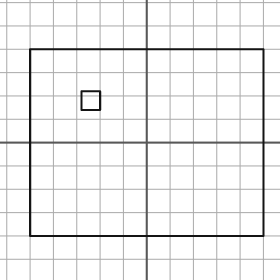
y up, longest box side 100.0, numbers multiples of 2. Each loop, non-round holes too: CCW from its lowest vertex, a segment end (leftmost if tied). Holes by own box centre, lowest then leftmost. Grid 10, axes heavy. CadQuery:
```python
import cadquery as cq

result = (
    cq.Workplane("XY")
    .moveTo(-50.0, -40.0)
    .lineTo(50.0, -40.0)
    .lineTo(50.0, 40.0)
    .lineTo(-50.0, 40.0)
    .close()
    .moveTo(-28.0, 14.0)
    .lineTo(-20.0, 14.0)
    .lineTo(-20.0, 22.0)
    .lineTo(-28.0, 22.0)
    .close()
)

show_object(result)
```